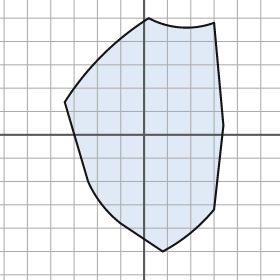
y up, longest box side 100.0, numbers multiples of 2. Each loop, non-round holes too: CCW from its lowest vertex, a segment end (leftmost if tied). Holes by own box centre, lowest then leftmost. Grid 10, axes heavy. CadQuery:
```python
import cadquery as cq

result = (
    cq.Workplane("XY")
    .moveTo(8.0, -50.0)
    .threePointArc((20.0, -42.0), (30.0, -32.0))
    .lineTo(34.0, 4.0)
    .lineTo(30.0, 48.0)
    .threePointArc((16.0, 46.0), (2.0, 50.0))
    .threePointArc((-18.0, 34.0), (-34.0, 14.0))
    .lineTo(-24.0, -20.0)
    .threePointArc((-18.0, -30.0), (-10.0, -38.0))
    .close()
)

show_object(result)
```